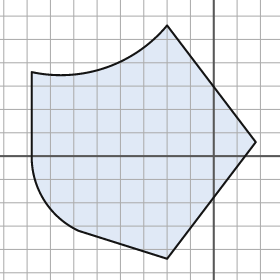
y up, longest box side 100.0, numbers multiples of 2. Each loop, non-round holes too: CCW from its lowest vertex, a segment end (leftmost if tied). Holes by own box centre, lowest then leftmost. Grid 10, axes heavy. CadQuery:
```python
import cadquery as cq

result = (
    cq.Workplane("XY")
    .moveTo(-20.0, -44.0)
    .lineTo(18.0, 6.0)
    .lineTo(-20.0, 56.0)
    .threePointArc((-46.0, 38.0), (-78.0, 36.0))
    .lineTo(-78.0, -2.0)
    .threePointArc((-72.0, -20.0), (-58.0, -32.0))
    .close()
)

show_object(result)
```